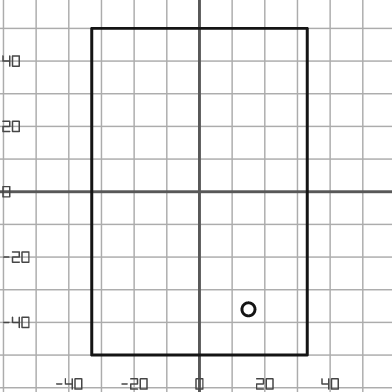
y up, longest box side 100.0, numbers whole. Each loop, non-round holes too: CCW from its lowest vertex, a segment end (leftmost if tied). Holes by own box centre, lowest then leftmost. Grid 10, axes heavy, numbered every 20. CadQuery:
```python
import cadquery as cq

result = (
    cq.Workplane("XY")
    .moveTo(-33.0, -50.0)
    .lineTo(33.0, -50.0)
    .lineTo(33.0, 50.0)
    .lineTo(-33.0, 50.0)
    .close()
    .moveTo(15.0, -36.0)
    .circle(2.0)
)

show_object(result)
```